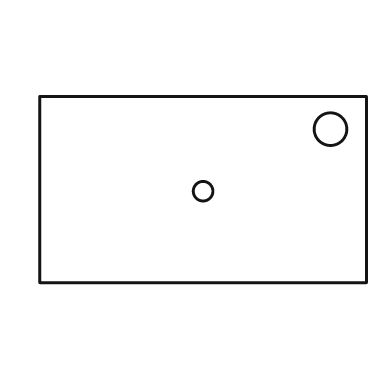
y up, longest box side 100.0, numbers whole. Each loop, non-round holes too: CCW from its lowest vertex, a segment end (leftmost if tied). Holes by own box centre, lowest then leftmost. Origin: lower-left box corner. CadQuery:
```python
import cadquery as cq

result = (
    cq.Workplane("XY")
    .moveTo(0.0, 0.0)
    .lineTo(100.0, 0.0)
    .lineTo(100.0, 57.0)
    .lineTo(0.0, 57.0)
    .close()
    .moveTo(50.0, 28.0)
    .circle(3.0)
    .moveTo(89.0, 47.0)
    .circle(5.0)
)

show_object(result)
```